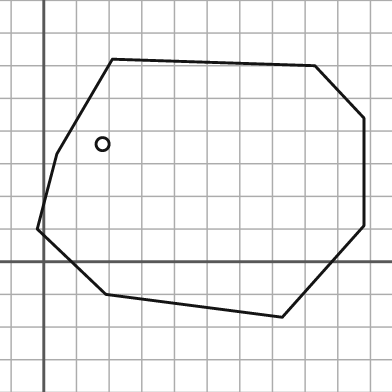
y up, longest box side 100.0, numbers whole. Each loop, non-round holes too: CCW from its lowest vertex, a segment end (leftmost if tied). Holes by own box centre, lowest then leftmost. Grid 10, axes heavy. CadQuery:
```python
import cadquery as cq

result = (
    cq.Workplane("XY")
    .moveTo(73.0, -17.0)
    .lineTo(98.0, 11.0)
    .lineTo(98.0, 44.0)
    .lineTo(83.0, 60.0)
    .lineTo(21.0, 62.0)
    .lineTo(4.0, 33.0)
    .lineTo(-2.0, 10.0)
    .lineTo(19.0, -10.0)
    .close()
    .moveTo(18.0, 36.0)
    .circle(2.0)
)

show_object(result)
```